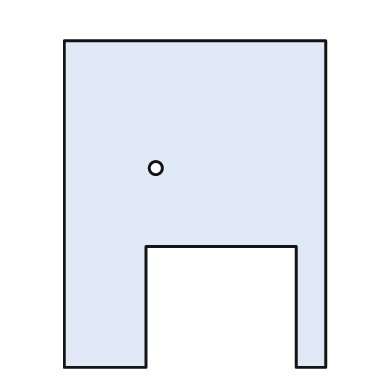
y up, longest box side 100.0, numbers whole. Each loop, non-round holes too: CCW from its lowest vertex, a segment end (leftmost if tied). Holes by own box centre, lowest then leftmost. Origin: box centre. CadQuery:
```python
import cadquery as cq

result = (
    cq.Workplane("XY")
    .moveTo(-40.0, -50.0)
    .lineTo(-15.0, -50.0)
    .lineTo(-15.0, -13.0)
    .lineTo(31.0, -13.0)
    .lineTo(31.0, -50.0)
    .lineTo(40.0, -50.0)
    .lineTo(40.0, 50.0)
    .lineTo(-40.0, 50.0)
    .close()
    .moveTo(-12.0, 11.0)
    .circle(2.0)
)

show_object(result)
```